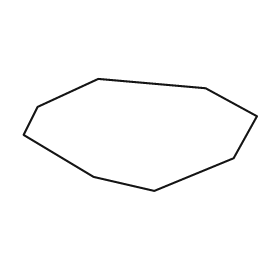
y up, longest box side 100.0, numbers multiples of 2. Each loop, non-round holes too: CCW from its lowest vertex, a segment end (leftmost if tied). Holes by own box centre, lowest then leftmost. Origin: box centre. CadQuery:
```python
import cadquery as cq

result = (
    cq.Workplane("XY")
    .moveTo(6.0, -24.0)
    .lineTo(40.0, -10.0)
    .lineTo(50.0, 8.0)
    .lineTo(28.0, 20.0)
    .lineTo(-18.0, 24.0)
    .lineTo(-44.0, 12.0)
    .lineTo(-50.0, 0.0)
    .lineTo(-20.0, -18.0)
    .close()
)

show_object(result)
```